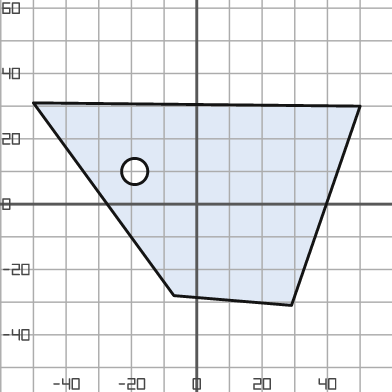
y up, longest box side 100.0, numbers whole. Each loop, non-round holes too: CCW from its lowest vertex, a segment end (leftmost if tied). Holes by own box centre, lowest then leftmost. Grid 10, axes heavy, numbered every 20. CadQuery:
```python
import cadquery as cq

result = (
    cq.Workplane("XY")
    .moveTo(29.0, -31.0)
    .lineTo(50.0, 30.0)
    .lineTo(-50.0, 31.0)
    .lineTo(-7.0, -28.0)
    .close()
    .moveTo(-19.0, 10.0)
    .circle(4.0)
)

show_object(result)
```